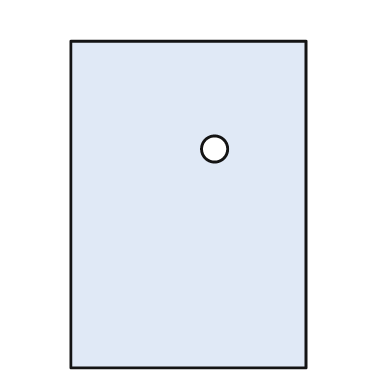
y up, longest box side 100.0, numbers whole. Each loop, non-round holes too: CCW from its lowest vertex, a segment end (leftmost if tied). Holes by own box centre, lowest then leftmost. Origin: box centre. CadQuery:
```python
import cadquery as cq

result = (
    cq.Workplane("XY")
    .moveTo(-36.0, -50.0)
    .lineTo(36.0, -50.0)
    .lineTo(36.0, 50.0)
    .lineTo(-36.0, 50.0)
    .close()
    .moveTo(8.0, 17.0)
    .circle(4.0)
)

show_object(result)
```